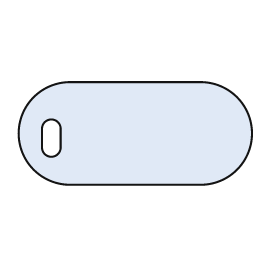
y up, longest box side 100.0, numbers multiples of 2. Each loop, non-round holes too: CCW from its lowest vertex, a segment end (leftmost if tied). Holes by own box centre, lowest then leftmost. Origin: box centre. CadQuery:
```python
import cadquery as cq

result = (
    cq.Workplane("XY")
    .moveTo(-28.0, -22.0)
    .lineTo(28.0, -22.0)
    .threePointArc((50.0, 0.0), (28.0, 22.0))
    .lineTo(-28.0, 22.0)
    .threePointArc((-50.0, 0.0), (-28.0, -22.0))
    .close()
    .moveTo(-40.0, -6.0)
    .threePointArc((-36.0, -10.0), (-32.0, -6.0))
    .lineTo(-32.0, 2.0)
    .threePointArc((-36.0, 6.0), (-40.0, 2.0))
    .close()
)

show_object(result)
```